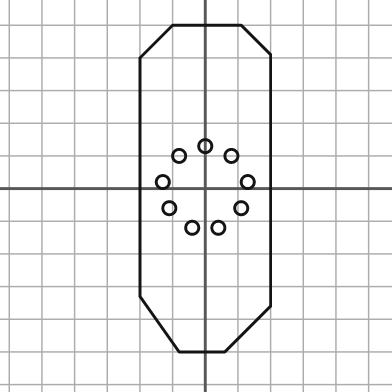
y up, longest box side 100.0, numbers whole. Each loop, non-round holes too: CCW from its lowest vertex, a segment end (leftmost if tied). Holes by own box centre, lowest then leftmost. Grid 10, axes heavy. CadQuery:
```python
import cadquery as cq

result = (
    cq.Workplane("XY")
    .moveTo(-8.0, -50.0)
    .lineTo(6.0, -50.0)
    .lineTo(20.0, -36.0)
    .lineTo(20.0, 41.0)
    .lineTo(11.0, 50.0)
    .lineTo(-10.0, 50.0)
    .lineTo(-20.0, 40.0)
    .lineTo(-20.0, -33.0)
    .close()
    .moveTo(-4.0, -12.0)
    .circle(2.0)
    .moveTo(4.0, -12.0)
    .circle(2.0)
    .moveTo(-11.0, -6.0)
    .circle(2.0)
    .moveTo(11.0, -6.0)
    .circle(2.0)
    .moveTo(-13.0, 2.0)
    .circle(2.0)
    .moveTo(13.0, 2.0)
    .circle(2.0)
    .moveTo(-8.0, 10.0)
    .circle(2.0)
    .moveTo(8.0, 10.0)
    .circle(2.0)
    .moveTo(0.0, 13.0)
    .circle(2.0)
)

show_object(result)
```